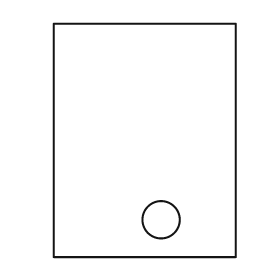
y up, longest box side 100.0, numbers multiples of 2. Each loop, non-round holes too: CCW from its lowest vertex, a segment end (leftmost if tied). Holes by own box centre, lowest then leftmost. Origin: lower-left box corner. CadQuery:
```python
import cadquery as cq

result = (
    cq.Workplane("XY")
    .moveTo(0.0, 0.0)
    .lineTo(78.0, 0.0)
    .lineTo(78.0, 100.0)
    .lineTo(0.0, 100.0)
    .close()
    .moveTo(46.0, 16.0)
    .circle(8.0)
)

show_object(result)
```